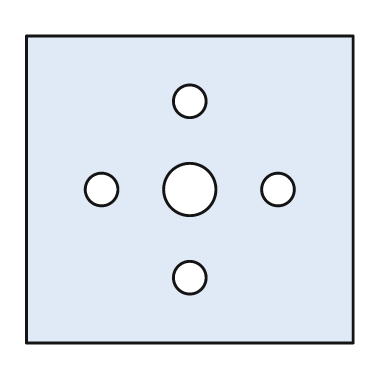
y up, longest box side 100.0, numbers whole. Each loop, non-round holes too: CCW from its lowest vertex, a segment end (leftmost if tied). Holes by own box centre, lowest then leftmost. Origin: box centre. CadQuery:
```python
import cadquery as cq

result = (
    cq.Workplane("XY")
    .moveTo(-50.0, -47.0)
    .lineTo(50.0, -47.0)
    .lineTo(50.0, 47.0)
    .lineTo(-50.0, 47.0)
    .close()
    .moveTo(0.0, -27.0)
    .circle(5.0)
    .moveTo(-27.0, 0.0)
    .circle(5.0)
    .moveTo(0.0, 0.0)
    .circle(8.0)
    .moveTo(27.0, 0.0)
    .circle(5.0)
    .moveTo(0.0, 27.0)
    .circle(5.0)
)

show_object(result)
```